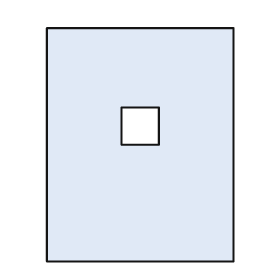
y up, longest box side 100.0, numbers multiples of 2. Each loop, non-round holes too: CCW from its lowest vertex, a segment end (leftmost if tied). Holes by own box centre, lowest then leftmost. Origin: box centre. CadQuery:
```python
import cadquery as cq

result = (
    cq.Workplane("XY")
    .moveTo(-40.0, -50.0)
    .lineTo(40.0, -50.0)
    .lineTo(40.0, 50.0)
    .lineTo(-40.0, 50.0)
    .close()
    .moveTo(-8.0, 0.0)
    .lineTo(8.0, 0.0)
    .lineTo(8.0, 16.0)
    .lineTo(-8.0, 16.0)
    .close()
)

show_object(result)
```